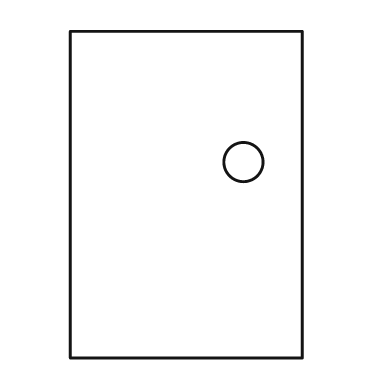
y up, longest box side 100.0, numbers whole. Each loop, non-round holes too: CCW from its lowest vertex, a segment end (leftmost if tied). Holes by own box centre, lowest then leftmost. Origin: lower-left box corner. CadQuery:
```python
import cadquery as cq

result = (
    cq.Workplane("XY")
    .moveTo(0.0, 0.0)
    .lineTo(71.0, 0.0)
    .lineTo(71.0, 100.0)
    .lineTo(0.0, 100.0)
    .close()
    .moveTo(53.0, 60.0)
    .circle(6.0)
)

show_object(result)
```